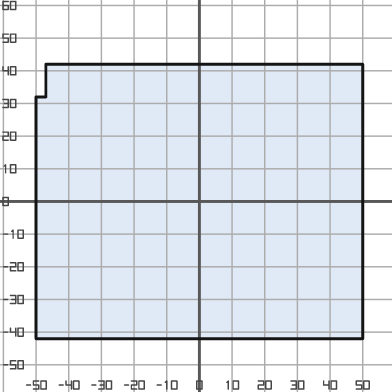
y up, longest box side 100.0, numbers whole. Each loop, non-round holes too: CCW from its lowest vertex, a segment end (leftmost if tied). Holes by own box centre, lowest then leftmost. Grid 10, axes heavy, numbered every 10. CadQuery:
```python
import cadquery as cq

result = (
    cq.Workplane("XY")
    .moveTo(-50.0, -42.0)
    .lineTo(50.0, -42.0)
    .lineTo(50.0, 42.0)
    .lineTo(-47.0, 42.0)
    .lineTo(-47.0, 32.0)
    .lineTo(-50.0, 32.0)
    .close()
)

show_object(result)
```